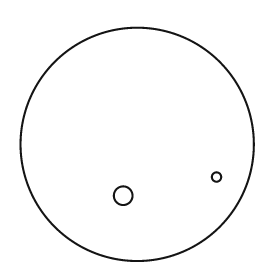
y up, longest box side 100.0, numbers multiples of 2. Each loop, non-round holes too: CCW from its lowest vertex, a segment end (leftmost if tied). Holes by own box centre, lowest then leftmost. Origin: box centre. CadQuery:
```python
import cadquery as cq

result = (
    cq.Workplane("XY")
    .moveTo(0.0, 0.0)
    .circle(50.0)
    .moveTo(-6.0, -22.0)
    .circle(4.0)
    .moveTo(34.0, -14.0)
    .circle(2.0)
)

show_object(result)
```